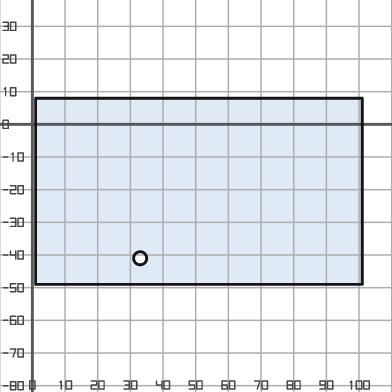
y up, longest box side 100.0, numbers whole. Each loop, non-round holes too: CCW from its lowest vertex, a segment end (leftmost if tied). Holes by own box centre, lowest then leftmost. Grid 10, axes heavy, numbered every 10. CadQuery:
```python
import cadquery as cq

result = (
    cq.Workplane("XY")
    .moveTo(1.0, -49.0)
    .lineTo(101.0, -49.0)
    .lineTo(101.0, 8.0)
    .lineTo(1.0, 8.0)
    .close()
    .moveTo(33.0, -41.0)
    .circle(2.0)
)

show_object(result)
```